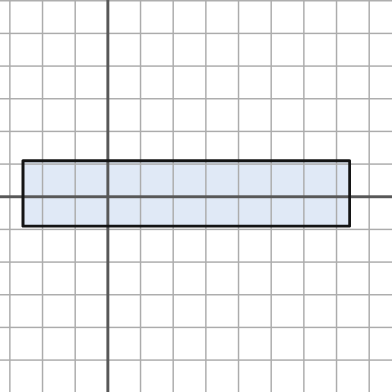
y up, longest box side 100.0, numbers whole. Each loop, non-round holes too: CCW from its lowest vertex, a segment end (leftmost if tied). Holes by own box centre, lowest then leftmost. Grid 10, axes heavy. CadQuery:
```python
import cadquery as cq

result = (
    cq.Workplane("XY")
    .moveTo(-26.0, -9.0)
    .lineTo(74.0, -9.0)
    .lineTo(74.0, 11.0)
    .lineTo(-26.0, 11.0)
    .close()
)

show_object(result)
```